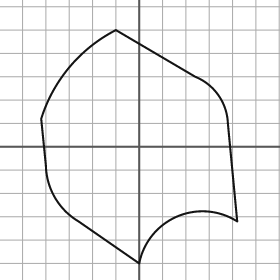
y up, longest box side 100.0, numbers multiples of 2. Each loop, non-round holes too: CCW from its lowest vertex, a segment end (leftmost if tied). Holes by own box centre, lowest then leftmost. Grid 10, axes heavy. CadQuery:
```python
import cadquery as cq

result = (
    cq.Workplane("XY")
    .moveTo(0.0, -50.0)
    .threePointArc((16.0, -30.0), (42.0, -32.0))
    .lineTo(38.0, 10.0)
    .threePointArc((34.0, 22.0), (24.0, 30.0))
    .lineTo(-10.0, 50.0)
    .threePointArc((-30.0, 34.0), (-42.0, 12.0))
    .lineTo(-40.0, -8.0)
    .threePointArc((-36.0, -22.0), (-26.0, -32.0))
    .close()
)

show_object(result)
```